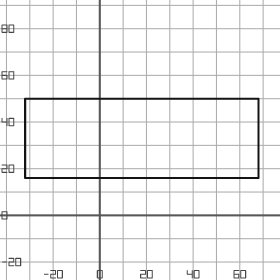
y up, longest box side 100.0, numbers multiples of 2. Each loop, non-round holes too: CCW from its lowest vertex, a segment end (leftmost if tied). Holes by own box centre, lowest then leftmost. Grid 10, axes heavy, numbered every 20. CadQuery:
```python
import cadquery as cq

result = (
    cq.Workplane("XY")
    .moveTo(-32.0, 16.0)
    .lineTo(68.0, 16.0)
    .lineTo(68.0, 50.0)
    .lineTo(-32.0, 50.0)
    .close()
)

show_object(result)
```